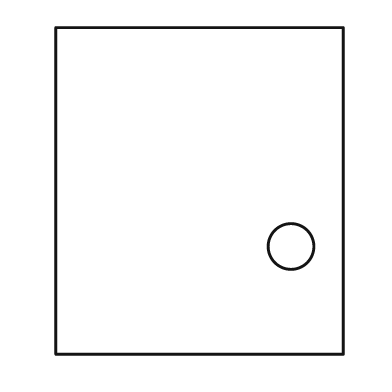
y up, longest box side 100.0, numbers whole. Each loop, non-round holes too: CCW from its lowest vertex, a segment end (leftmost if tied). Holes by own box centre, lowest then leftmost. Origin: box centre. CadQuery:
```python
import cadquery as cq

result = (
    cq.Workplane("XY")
    .moveTo(-44.0, -50.0)
    .lineTo(44.0, -50.0)
    .lineTo(44.0, 50.0)
    .lineTo(-44.0, 50.0)
    .close()
    .moveTo(28.0, -17.0)
    .circle(7.0)
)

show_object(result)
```